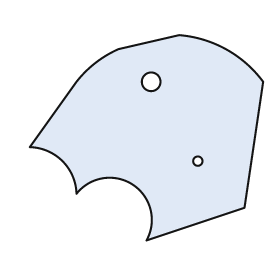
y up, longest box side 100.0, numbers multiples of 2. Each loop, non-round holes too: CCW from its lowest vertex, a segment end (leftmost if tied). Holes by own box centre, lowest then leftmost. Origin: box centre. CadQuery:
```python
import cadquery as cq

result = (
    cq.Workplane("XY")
    .moveTo(0.0, -44.0)
    .lineTo(42.0, -30.0)
    .lineTo(50.0, 24.0)
    .threePointArc((34.0, 38.0), (14.0, 44.0))
    .lineTo(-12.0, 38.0)
    .threePointArc((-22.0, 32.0), (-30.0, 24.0))
    .lineTo(-50.0, -4.0)
    .threePointArc((-36.0, -10.0), (-30.0, -24.0))
    .threePointArc((-6.0, -20.0), (0.0, -44.0))
    .close()
    .moveTo(22.0, -10.0)
    .circle(2.0)
    .moveTo(2.0, 24.0)
    .circle(4.0)
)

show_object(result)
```